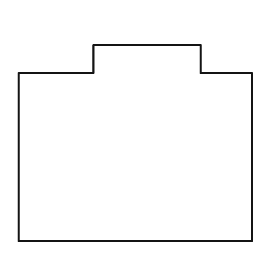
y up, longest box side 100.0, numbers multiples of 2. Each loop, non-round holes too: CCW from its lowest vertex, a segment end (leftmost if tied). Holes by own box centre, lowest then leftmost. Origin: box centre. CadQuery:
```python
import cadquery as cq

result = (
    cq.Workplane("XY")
    .moveTo(-50.0, -42.0)
    .lineTo(50.0, -42.0)
    .lineTo(50.0, 30.0)
    .lineTo(28.0, 30.0)
    .lineTo(28.0, 42.0)
    .lineTo(-18.0, 42.0)
    .lineTo(-18.0, 30.0)
    .lineTo(-50.0, 30.0)
    .close()
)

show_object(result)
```